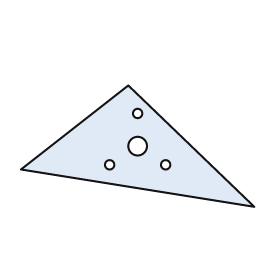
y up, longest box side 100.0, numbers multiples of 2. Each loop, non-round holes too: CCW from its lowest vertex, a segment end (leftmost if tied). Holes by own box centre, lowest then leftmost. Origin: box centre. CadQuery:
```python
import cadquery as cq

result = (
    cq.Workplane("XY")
    .moveTo(50.0, -26.0)
    .lineTo(-4.0, 26.0)
    .lineTo(-50.0, -10.0)
    .close()
    .moveTo(-12.0, -8.0)
    .circle(2.0)
    .moveTo(12.0, -8.0)
    .circle(2.0)
    .moveTo(0.0, 0.0)
    .circle(4.0)
    .moveTo(0.0, 14.0)
    .circle(2.0)
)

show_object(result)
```